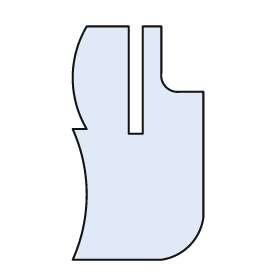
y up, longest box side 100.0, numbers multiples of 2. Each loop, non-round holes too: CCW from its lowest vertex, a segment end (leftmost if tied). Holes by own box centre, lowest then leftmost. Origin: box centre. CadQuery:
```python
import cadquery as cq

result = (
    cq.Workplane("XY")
    .moveTo(-28.0, -50.0)
    .lineTo(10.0, -50.0)
    .threePointArc((22.0, -44.0), (28.0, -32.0))
    .lineTo(28.0, 22.0)
    .lineTo(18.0, 22.0)
    .threePointArc((12.0, 24.0), (10.0, 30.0))
    .lineTo(10.0, 50.0)
    .lineTo(2.0, 50.0)
    .lineTo(2.0, 4.0)
    .lineTo(-4.0, 4.0)
    .lineTo(-4.0, 50.0)
    .lineTo(-22.0, 50.0)
    .threePointArc((-28.0, 28.0), (-22.0, 6.0))
    .lineTo(-28.0, 6.0)
    .threePointArc((-22.0, -22.0), (-28.0, -50.0))
    .close()
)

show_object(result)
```